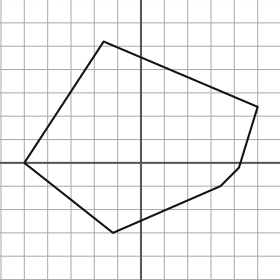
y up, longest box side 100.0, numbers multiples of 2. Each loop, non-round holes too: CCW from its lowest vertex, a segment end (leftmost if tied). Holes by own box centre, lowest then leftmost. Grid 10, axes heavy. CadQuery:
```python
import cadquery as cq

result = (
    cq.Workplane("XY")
    .moveTo(-12.0, -30.0)
    .lineTo(34.0, -10.0)
    .lineTo(42.0, -2.0)
    .lineTo(50.0, 24.0)
    .lineTo(-16.0, 52.0)
    .lineTo(-50.0, 0.0)
    .close()
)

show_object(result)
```